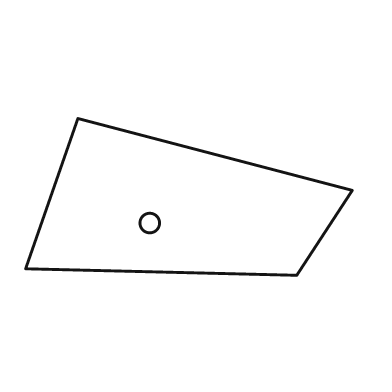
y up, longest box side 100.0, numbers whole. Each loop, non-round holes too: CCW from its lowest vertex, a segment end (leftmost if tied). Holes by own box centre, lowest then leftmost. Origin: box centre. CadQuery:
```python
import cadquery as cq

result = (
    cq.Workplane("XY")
    .moveTo(33.0, -24.0)
    .lineTo(50.0, 2.0)
    .lineTo(-34.0, 24.0)
    .lineTo(-50.0, -22.0)
    .close()
    .moveTo(-12.0, -8.0)
    .circle(3.0)
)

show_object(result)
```